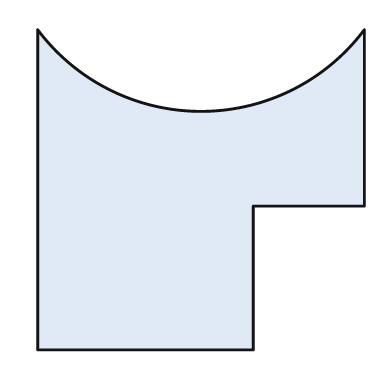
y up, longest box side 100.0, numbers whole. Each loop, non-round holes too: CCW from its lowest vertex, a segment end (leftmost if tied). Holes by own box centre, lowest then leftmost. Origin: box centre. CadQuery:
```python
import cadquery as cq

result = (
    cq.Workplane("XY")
    .moveTo(-50.0, -49.0)
    .lineTo(16.0, -49.0)
    .lineTo(16.0, -5.0)
    .lineTo(50.0, -5.0)
    .lineTo(50.0, 49.0)
    .threePointArc((0.0, 24.0), (-50.0, 49.0))
    .close()
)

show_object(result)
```